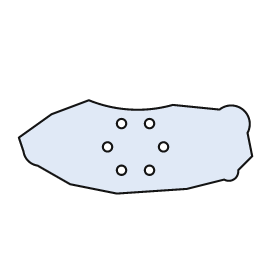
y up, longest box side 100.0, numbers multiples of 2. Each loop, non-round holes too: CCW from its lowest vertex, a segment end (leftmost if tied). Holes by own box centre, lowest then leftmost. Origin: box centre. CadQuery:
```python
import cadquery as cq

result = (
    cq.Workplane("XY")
    .moveTo(-8.0, -20.0)
    .lineTo(22.0, -18.0)
    .lineTo(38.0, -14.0)
    .threePointArc((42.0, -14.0), (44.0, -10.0))
    .lineTo(50.0, -4.0)
    .lineTo(48.0, 6.0)
    .threePointArc((46.0, 16.0), (36.0, 16.0))
    .lineTo(16.0, 18.0)
    .threePointArc((-2.0, 16.0), (-20.0, 20.0))
    .lineTo(-36.0, 14.0)
    .lineTo(-50.0, 4.0)
    .lineTo(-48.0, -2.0)
    .threePointArc((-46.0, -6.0), (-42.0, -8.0))
    .lineTo(-28.0, -16.0)
    .close()
    .moveTo(-6.0, -10.0)
    .circle(2.0)
    .moveTo(6.0, -10.0)
    .circle(2.0)
    .moveTo(-12.0, 0.0)
    .circle(2.0)
    .moveTo(12.0, 0.0)
    .circle(2.0)
    .moveTo(-6.0, 10.0)
    .circle(2.0)
    .moveTo(6.0, 10.0)
    .circle(2.0)
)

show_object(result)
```